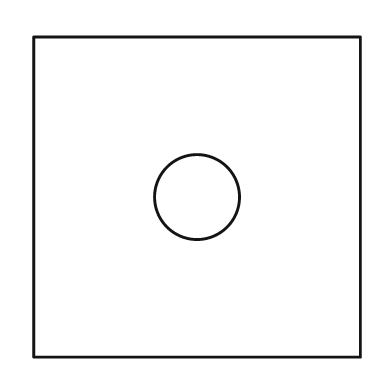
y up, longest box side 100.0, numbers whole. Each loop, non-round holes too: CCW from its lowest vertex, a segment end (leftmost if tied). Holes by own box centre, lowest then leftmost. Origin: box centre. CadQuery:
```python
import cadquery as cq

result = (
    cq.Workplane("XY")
    .moveTo(-50.0, -49.0)
    .lineTo(50.0, -49.0)
    .lineTo(50.0, 49.0)
    .lineTo(-50.0, 49.0)
    .close()
    .moveTo(0.0, 0.0)
    .circle(13.0)
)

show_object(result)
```